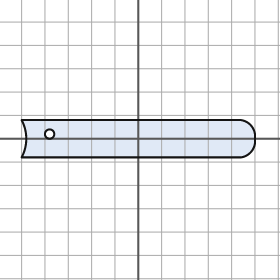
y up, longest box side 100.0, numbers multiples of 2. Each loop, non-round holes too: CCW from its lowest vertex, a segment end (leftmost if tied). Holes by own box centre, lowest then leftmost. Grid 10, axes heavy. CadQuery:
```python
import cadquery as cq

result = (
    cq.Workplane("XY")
    .moveTo(-50.0, -8.0)
    .lineTo(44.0, -8.0)
    .threePointArc((48.0, -6.0), (50.0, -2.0))
    .lineTo(50.0, 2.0)
    .threePointArc((48.0, 6.0), (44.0, 8.0))
    .lineTo(-50.0, 8.0)
    .threePointArc((-48.0, 0.0), (-50.0, -8.0))
    .close()
    .moveTo(-38.0, 2.0)
    .circle(2.0)
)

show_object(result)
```